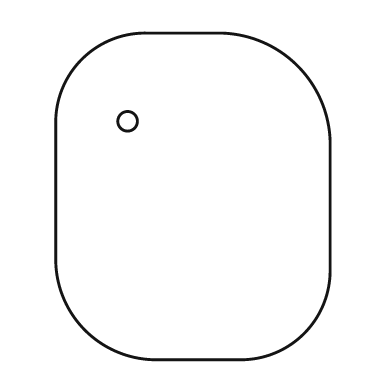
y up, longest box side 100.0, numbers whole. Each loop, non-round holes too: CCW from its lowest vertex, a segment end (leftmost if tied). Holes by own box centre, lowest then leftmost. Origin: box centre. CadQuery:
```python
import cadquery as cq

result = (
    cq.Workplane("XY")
    .moveTo(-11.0, -50.0)
    .lineTo(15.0, -50.0)
    .threePointArc((34.0, -42.0), (42.0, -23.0))
    .lineTo(42.0, 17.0)
    .threePointArc((32.0, 40.0), (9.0, 50.0))
    .lineTo(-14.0, 50.0)
    .threePointArc((-34.0, 42.0), (-42.0, 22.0))
    .lineTo(-42.0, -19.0)
    .threePointArc((-33.0, -41.0), (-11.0, -50.0))
    .close()
    .moveTo(-20.0, 23.0)
    .circle(3.0)
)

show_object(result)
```